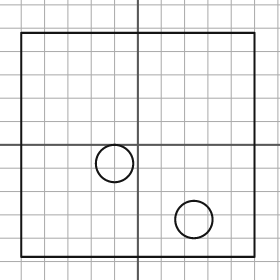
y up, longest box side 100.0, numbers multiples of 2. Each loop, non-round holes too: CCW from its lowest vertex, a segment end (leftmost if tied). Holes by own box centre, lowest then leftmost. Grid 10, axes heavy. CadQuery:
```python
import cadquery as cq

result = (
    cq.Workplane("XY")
    .moveTo(-50.0, -48.0)
    .lineTo(50.0, -48.0)
    .lineTo(50.0, 48.0)
    .lineTo(-50.0, 48.0)
    .close()
    .moveTo(24.0, -32.0)
    .circle(8.0)
    .moveTo(-10.0, -8.0)
    .circle(8.0)
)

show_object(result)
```